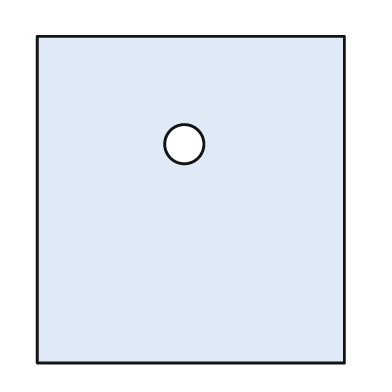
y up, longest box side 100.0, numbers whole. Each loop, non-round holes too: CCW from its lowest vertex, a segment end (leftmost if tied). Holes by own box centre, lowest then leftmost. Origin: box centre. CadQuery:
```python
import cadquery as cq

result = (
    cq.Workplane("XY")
    .moveTo(-47.0, -50.0)
    .lineTo(47.0, -50.0)
    .lineTo(47.0, 50.0)
    .lineTo(-47.0, 50.0)
    .close()
    .moveTo(-2.0, 17.0)
    .circle(6.0)
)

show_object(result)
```